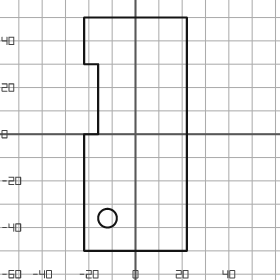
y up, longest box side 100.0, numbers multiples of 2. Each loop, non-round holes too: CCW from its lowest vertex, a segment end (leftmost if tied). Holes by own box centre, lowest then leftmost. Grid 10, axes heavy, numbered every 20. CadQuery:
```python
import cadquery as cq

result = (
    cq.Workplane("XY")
    .moveTo(-22.0, -50.0)
    .lineTo(22.0, -50.0)
    .lineTo(22.0, 50.0)
    .lineTo(-22.0, 50.0)
    .lineTo(-22.0, 30.0)
    .lineTo(-16.0, 30.0)
    .lineTo(-16.0, 0.0)
    .lineTo(-22.0, 0.0)
    .close()
    .moveTo(-12.0, -36.0)
    .circle(4.0)
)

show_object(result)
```